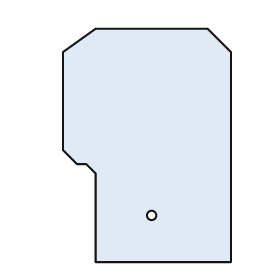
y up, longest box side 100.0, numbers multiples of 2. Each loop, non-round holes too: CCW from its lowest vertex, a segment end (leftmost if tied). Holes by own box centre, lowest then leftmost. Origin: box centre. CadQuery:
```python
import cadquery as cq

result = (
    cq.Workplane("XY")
    .moveTo(-22.0, -50.0)
    .lineTo(36.0, -50.0)
    .lineTo(36.0, 40.0)
    .lineTo(26.0, 50.0)
    .lineTo(-22.0, 50.0)
    .lineTo(-36.0, 40.0)
    .lineTo(-36.0, -2.0)
    .lineTo(-30.0, -8.0)
    .lineTo(-26.0, -8.0)
    .lineTo(-22.0, -12.0)
    .close()
    .moveTo(2.0, -30.0)
    .circle(2.0)
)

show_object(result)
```